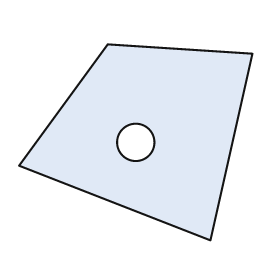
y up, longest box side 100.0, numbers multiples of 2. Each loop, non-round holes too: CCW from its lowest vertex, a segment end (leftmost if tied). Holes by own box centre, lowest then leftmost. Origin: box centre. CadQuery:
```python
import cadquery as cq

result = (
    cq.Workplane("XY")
    .moveTo(32.0, -42.0)
    .lineTo(50.0, 38.0)
    .lineTo(-12.0, 42.0)
    .lineTo(-50.0, -10.0)
    .close()
    .moveTo(0.0, 0.0)
    .circle(8.0)
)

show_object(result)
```